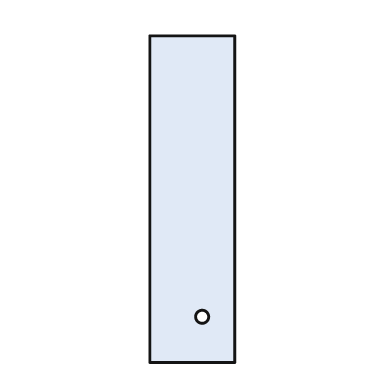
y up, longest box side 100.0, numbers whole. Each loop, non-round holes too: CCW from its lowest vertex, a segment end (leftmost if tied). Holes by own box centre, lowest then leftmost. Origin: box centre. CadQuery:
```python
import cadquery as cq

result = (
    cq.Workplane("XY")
    .moveTo(-13.0, -50.0)
    .lineTo(13.0, -50.0)
    .lineTo(13.0, 50.0)
    .lineTo(-13.0, 50.0)
    .close()
    .moveTo(3.0, -36.0)
    .circle(2.0)
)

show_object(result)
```